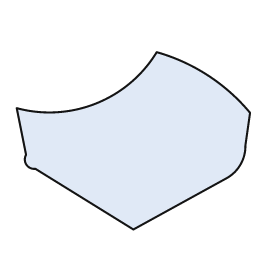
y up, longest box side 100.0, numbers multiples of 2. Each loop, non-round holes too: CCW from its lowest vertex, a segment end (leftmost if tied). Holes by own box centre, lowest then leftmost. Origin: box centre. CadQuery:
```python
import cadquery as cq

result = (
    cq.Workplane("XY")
    .moveTo(0.0, -38.0)
    .lineTo(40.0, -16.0)
    .threePointArc((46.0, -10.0), (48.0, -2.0))
    .lineTo(50.0, 12.0)
    .threePointArc((32.0, 28.0), (10.0, 38.0))
    .threePointArc((-16.0, 16.0), (-50.0, 14.0))
    .lineTo(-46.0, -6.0)
    .threePointArc((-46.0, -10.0), (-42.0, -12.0))
    .close()
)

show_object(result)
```